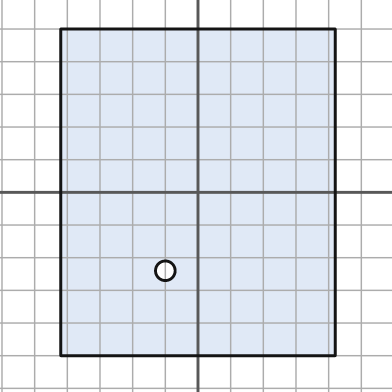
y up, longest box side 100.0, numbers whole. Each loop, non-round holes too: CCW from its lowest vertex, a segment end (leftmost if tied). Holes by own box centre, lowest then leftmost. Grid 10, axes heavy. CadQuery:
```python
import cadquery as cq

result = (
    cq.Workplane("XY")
    .moveTo(-42.0, -50.0)
    .lineTo(42.0, -50.0)
    .lineTo(42.0, 50.0)
    .lineTo(-42.0, 50.0)
    .close()
    .moveTo(-10.0, -24.0)
    .circle(3.0)
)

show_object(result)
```